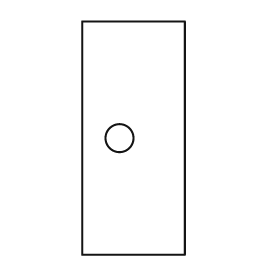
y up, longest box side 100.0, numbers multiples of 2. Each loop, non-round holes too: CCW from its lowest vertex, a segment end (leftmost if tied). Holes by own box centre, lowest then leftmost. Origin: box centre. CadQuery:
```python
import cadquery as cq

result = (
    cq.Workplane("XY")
    .moveTo(-22.0, -50.0)
    .lineTo(22.0, -50.0)
    .lineTo(22.0, 50.0)
    .lineTo(-22.0, 50.0)
    .close()
    .moveTo(-6.0, 0.0)
    .circle(6.0)
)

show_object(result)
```